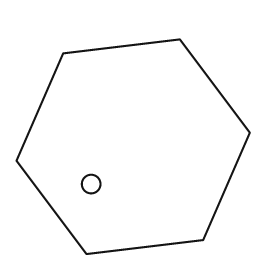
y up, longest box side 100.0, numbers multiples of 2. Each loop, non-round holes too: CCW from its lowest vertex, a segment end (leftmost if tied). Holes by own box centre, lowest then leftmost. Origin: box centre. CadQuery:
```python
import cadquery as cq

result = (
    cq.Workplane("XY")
    .moveTo(-20.0, -46.0)
    .lineTo(30.0, -40.0)
    .lineTo(50.0, 6.0)
    .lineTo(20.0, 46.0)
    .lineTo(-30.0, 40.0)
    .lineTo(-50.0, -6.0)
    .close()
    .moveTo(-18.0, -16.0)
    .circle(4.0)
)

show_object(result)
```